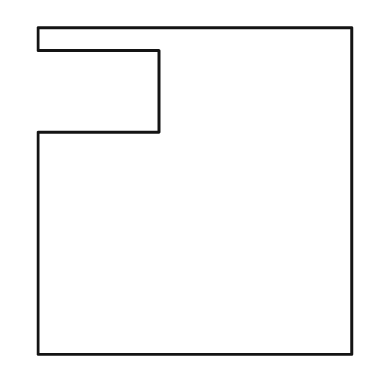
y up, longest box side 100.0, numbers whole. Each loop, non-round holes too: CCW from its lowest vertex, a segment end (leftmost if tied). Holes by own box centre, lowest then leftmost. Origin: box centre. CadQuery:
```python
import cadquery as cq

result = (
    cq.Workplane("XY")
    .moveTo(-48.0, -50.0)
    .lineTo(48.0, -50.0)
    .lineTo(48.0, 50.0)
    .lineTo(-48.0, 50.0)
    .lineTo(-48.0, 43.0)
    .lineTo(-11.0, 43.0)
    .lineTo(-11.0, 18.0)
    .lineTo(-48.0, 18.0)
    .close()
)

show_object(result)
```